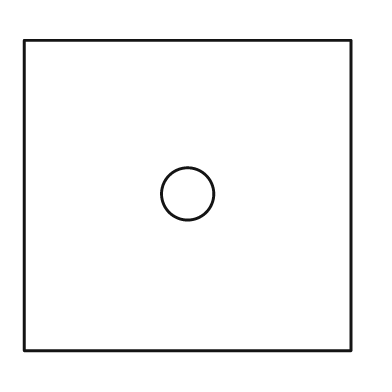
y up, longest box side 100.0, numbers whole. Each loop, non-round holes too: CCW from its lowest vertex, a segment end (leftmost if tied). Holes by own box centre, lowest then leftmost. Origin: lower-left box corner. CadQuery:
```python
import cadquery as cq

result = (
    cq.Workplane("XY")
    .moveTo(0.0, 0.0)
    .lineTo(100.0, 0.0)
    .lineTo(100.0, 95.0)
    .lineTo(0.0, 95.0)
    .close()
    .moveTo(50.0, 48.0)
    .circle(8.0)
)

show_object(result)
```